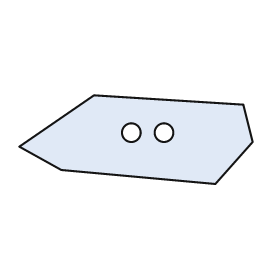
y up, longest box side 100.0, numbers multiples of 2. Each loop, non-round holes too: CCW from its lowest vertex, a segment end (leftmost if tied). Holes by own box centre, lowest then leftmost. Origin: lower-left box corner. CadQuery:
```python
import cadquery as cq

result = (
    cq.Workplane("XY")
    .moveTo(84.0, 0.0)
    .lineTo(100.0, 18.0)
    .lineTo(96.0, 34.0)
    .lineTo(32.0, 38.0)
    .lineTo(0.0, 16.0)
    .lineTo(18.0, 6.0)
    .close()
    .moveTo(48.0, 22.0)
    .circle(4.0)
    .moveTo(62.0, 22.0)
    .circle(4.0)
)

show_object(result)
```